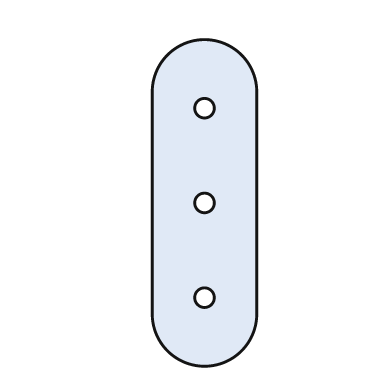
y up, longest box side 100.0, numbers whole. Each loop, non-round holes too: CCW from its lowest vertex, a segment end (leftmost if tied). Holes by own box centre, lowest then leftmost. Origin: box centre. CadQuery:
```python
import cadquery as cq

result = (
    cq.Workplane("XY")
    .moveTo(-16.0, -34.0)
    .threePointArc((0.0, -50.0), (16.0, -34.0))
    .lineTo(16.0, 34.0)
    .threePointArc((0.0, 50.0), (-16.0, 34.0))
    .close()
    .moveTo(0.0, -29.0)
    .circle(3.0)
    .moveTo(0.0, 0.0)
    .circle(3.0)
    .moveTo(0.0, 29.0)
    .circle(3.0)
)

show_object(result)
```